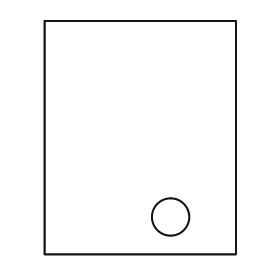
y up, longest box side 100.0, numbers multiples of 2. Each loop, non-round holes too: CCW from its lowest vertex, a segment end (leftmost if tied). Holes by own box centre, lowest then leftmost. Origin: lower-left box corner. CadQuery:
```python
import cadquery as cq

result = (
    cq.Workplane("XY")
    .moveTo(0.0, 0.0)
    .lineTo(82.0, 0.0)
    .lineTo(82.0, 100.0)
    .lineTo(0.0, 100.0)
    .close()
    .moveTo(54.0, 16.0)
    .circle(8.0)
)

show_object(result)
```